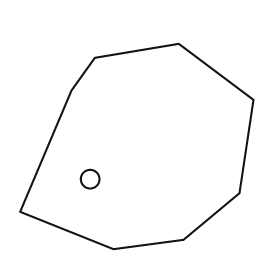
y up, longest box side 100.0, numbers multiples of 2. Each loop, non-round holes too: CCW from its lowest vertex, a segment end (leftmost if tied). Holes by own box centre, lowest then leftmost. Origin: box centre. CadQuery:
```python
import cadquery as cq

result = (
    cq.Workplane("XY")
    .moveTo(-10.0, -44.0)
    .lineTo(20.0, -40.0)
    .lineTo(44.0, -20.0)
    .lineTo(50.0, 20.0)
    .lineTo(18.0, 44.0)
    .lineTo(-18.0, 38.0)
    .lineTo(-28.0, 24.0)
    .lineTo(-50.0, -28.0)
    .close()
    .moveTo(-20.0, -14.0)
    .circle(4.0)
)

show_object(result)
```